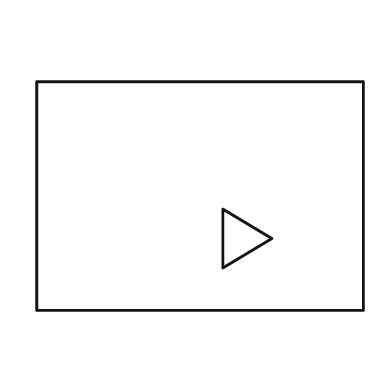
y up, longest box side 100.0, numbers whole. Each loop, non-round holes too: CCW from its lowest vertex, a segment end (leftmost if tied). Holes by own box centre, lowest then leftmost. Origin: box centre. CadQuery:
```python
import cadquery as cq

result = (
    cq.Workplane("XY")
    .moveTo(-50.0, -35.0)
    .lineTo(50.0, -35.0)
    .lineTo(50.0, 35.0)
    .lineTo(-50.0, 35.0)
    .close()
    .moveTo(7.0, -22.0)
    .lineTo(22.0, -13.0)
    .lineTo(7.0, -4.0)
    .close()
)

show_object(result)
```